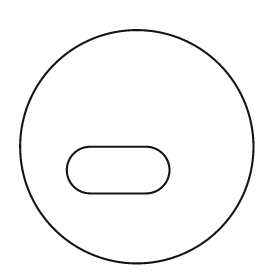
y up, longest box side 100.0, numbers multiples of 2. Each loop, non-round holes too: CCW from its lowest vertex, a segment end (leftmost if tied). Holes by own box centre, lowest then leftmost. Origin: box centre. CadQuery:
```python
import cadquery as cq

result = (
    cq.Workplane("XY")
    .moveTo(0.0, 0.0)
    .circle(50.0)
    .moveTo(-20.0, -20.0)
    .lineTo(4.0, -20.0)
    .threePointArc((14.0, -10.0), (4.0, 0.0))
    .lineTo(-20.0, 0.0)
    .threePointArc((-30.0, -10.0), (-20.0, -20.0))
    .close()
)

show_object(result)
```